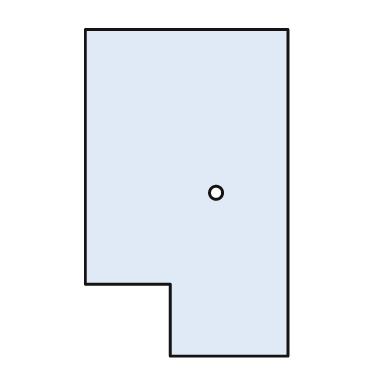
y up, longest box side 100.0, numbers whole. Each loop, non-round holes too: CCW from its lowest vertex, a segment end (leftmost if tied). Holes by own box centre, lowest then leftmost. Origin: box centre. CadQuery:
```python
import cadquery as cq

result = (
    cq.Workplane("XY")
    .moveTo(-5.0, -50.0)
    .lineTo(31.0, -50.0)
    .lineTo(31.0, 50.0)
    .lineTo(-31.0, 50.0)
    .lineTo(-31.0, -28.0)
    .lineTo(-5.0, -28.0)
    .close()
    .moveTo(9.0, 0.0)
    .circle(2.0)
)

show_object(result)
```